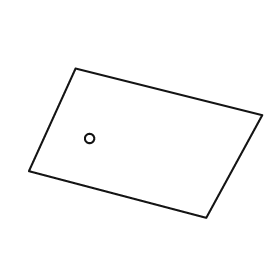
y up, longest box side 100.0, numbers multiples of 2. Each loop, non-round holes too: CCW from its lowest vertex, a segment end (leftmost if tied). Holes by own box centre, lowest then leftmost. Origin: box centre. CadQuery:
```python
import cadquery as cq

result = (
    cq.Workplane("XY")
    .moveTo(26.0, -32.0)
    .lineTo(50.0, 12.0)
    .lineTo(-30.0, 32.0)
    .lineTo(-50.0, -12.0)
    .close()
    .moveTo(-24.0, 2.0)
    .circle(2.0)
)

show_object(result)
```